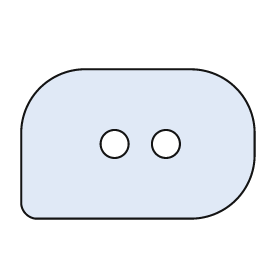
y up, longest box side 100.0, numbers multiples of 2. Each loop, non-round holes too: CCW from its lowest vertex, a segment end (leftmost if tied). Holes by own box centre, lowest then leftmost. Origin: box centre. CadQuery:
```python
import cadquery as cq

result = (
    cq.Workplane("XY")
    .moveTo(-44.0, -32.0)
    .lineTo(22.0, -32.0)
    .threePointArc((42.0, -24.0), (50.0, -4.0))
    .lineTo(50.0, 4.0)
    .threePointArc((42.0, 24.0), (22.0, 32.0))
    .lineTo(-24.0, 32.0)
    .threePointArc((-42.0, 24.0), (-50.0, 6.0))
    .lineTo(-50.0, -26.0)
    .threePointArc((-48.0, -30.0), (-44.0, -32.0))
    .close()
    .moveTo(-10.0, 0.0)
    .circle(6.0)
    .moveTo(12.0, 0.0)
    .circle(6.0)
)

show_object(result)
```